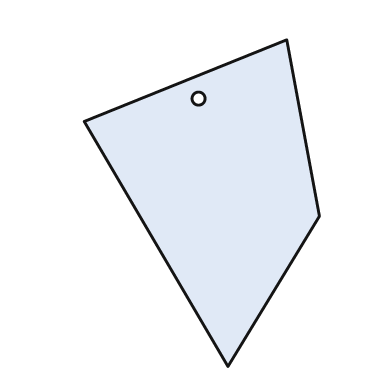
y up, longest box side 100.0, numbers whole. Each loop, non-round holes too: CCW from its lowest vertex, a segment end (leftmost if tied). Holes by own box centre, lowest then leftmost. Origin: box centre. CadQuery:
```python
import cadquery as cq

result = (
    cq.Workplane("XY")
    .moveTo(8.0, -50.0)
    .lineTo(36.0, -4.0)
    .lineTo(26.0, 50.0)
    .lineTo(-36.0, 25.0)
    .close()
    .moveTo(-1.0, 32.0)
    .circle(2.0)
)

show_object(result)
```